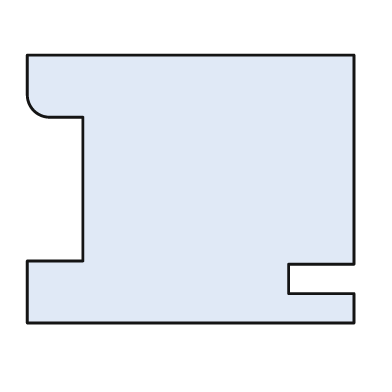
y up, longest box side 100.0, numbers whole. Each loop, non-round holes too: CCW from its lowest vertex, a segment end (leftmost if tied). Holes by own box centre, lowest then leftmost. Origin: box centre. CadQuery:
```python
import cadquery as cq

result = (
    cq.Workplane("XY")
    .moveTo(-50.0, -41.0)
    .lineTo(50.0, -41.0)
    .lineTo(50.0, -32.0)
    .lineTo(30.0, -32.0)
    .lineTo(30.0, -23.0)
    .lineTo(50.0, -23.0)
    .lineTo(50.0, 41.0)
    .lineTo(-50.0, 41.0)
    .lineTo(-50.0, 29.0)
    .threePointArc((-48.0, 24.0), (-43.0, 22.0))
    .lineTo(-33.0, 22.0)
    .lineTo(-33.0, -22.0)
    .lineTo(-50.0, -22.0)
    .close()
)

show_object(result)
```